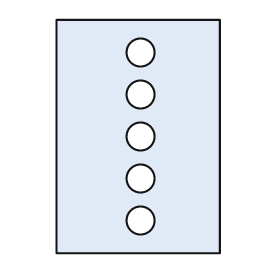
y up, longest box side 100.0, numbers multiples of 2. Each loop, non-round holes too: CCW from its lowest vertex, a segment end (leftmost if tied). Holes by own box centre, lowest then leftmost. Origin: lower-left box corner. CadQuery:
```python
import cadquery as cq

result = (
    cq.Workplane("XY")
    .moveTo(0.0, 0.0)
    .lineTo(70.0, 0.0)
    .lineTo(70.0, 100.0)
    .lineTo(0.0, 100.0)
    .close()
    .moveTo(36.0, 14.0)
    .circle(6.0)
    .moveTo(36.0, 32.0)
    .circle(6.0)
    .moveTo(36.0, 50.0)
    .circle(6.0)
    .moveTo(36.0, 68.0)
    .circle(6.0)
    .moveTo(36.0, 86.0)
    .circle(6.0)
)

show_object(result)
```